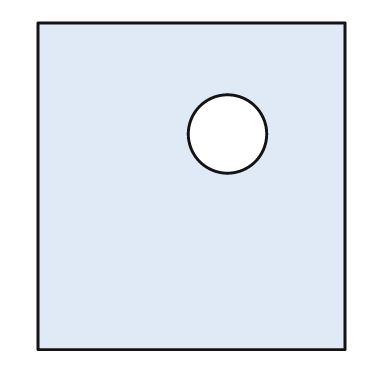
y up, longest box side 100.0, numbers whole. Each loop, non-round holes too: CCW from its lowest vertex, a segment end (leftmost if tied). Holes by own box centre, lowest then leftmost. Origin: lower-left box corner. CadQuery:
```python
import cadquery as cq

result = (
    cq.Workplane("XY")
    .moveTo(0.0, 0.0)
    .lineTo(94.0, 0.0)
    .lineTo(94.0, 100.0)
    .lineTo(0.0, 100.0)
    .close()
    .moveTo(58.0, 66.0)
    .circle(12.0)
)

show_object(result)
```